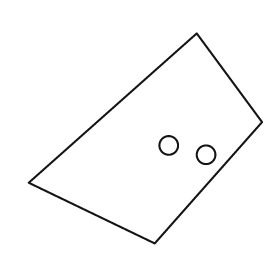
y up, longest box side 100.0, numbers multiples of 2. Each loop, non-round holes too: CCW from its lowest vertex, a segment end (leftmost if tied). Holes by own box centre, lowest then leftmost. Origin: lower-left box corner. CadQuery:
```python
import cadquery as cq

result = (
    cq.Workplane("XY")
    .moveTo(54.0, 0.0)
    .lineTo(100.0, 52.0)
    .lineTo(72.0, 90.0)
    .lineTo(0.0, 26.0)
    .close()
    .moveTo(76.0, 38.0)
    .circle(4.0)
    .moveTo(60.0, 42.0)
    .circle(4.0)
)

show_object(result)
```